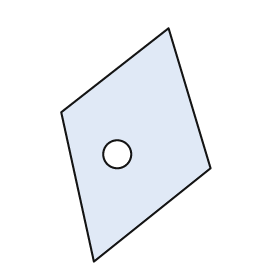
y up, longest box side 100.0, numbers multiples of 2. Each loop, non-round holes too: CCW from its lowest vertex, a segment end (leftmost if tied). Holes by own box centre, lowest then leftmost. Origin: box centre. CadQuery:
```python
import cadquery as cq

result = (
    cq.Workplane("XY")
    .moveTo(-18.0, -50.0)
    .lineTo(32.0, -10.0)
    .lineTo(14.0, 50.0)
    .lineTo(-32.0, 14.0)
    .close()
    .moveTo(-8.0, -4.0)
    .circle(6.0)
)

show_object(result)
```